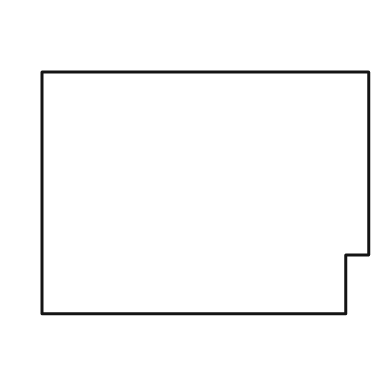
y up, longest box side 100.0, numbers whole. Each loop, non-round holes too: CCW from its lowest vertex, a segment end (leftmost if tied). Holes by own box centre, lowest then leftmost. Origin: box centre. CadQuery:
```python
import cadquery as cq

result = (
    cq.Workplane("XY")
    .moveTo(-50.0, -37.0)
    .lineTo(43.0, -37.0)
    .lineTo(43.0, -19.0)
    .lineTo(50.0, -19.0)
    .lineTo(50.0, 37.0)
    .lineTo(-50.0, 37.0)
    .close()
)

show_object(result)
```